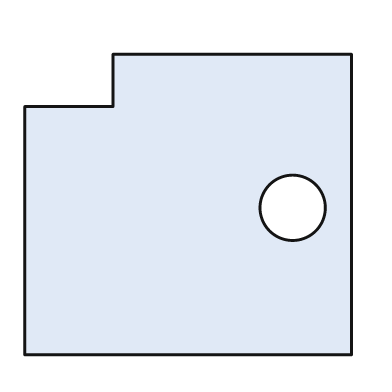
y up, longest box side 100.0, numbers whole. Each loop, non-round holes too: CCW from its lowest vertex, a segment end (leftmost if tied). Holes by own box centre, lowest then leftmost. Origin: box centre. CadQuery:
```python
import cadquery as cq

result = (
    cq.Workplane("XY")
    .moveTo(-50.0, -46.0)
    .lineTo(50.0, -46.0)
    .lineTo(50.0, 46.0)
    .lineTo(-23.0, 46.0)
    .lineTo(-23.0, 30.0)
    .lineTo(-50.0, 30.0)
    .close()
    .moveTo(32.0, -1.0)
    .circle(10.0)
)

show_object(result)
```